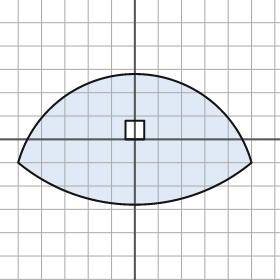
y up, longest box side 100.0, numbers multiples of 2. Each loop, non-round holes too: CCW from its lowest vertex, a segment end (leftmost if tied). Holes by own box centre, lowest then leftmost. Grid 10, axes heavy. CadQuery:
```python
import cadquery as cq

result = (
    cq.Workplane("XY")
    .moveTo(-50.0, -10.0)
    .threePointArc((0.0, -28.0), (50.0, -10.0))
    .threePointArc((0.0, 28.0), (-50.0, -10.0))
    .close()
    .moveTo(-4.0, 0.0)
    .lineTo(4.0, 0.0)
    .lineTo(4.0, 8.0)
    .lineTo(-4.0, 8.0)
    .close()
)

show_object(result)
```